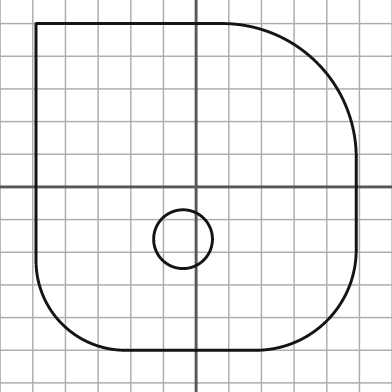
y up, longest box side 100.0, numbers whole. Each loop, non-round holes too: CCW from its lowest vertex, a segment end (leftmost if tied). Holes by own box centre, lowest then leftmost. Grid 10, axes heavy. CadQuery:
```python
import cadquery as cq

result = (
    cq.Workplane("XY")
    .moveTo(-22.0, -50.0)
    .lineTo(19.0, -50.0)
    .threePointArc((40.0, -41.0), (49.0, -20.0))
    .lineTo(49.0, 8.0)
    .threePointArc((37.0, 38.0), (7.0, 50.0))
    .lineTo(-49.0, 50.0)
    .lineTo(-49.0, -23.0)
    .threePointArc((-41.0, -42.0), (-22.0, -50.0))
    .close()
    .moveTo(-4.0, -16.0)
    .circle(9.0)
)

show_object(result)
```